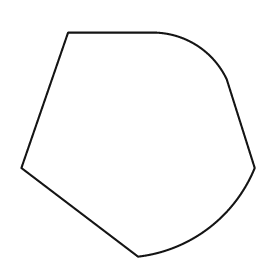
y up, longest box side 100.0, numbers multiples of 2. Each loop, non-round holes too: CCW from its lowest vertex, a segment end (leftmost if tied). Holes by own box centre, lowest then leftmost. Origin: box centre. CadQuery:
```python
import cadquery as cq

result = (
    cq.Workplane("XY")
    .moveTo(0.0, -48.0)
    .threePointArc((30.0, -36.0), (50.0, -10.0))
    .lineTo(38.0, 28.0)
    .threePointArc((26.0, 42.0), (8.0, 48.0))
    .lineTo(-30.0, 48.0)
    .lineTo(-50.0, -10.0)
    .close()
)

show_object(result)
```